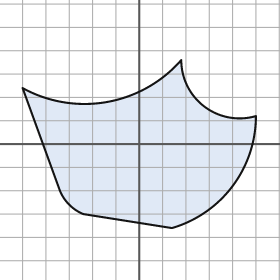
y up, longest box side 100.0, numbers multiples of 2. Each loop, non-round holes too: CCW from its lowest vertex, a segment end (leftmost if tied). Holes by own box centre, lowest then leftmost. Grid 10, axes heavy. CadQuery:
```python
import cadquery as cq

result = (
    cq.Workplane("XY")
    .moveTo(14.0, -36.0)
    .threePointArc((40.0, -18.0), (50.0, 12.0))
    .threePointArc((28.0, 16.0), (18.0, 36.0))
    .threePointArc((-14.0, 18.0), (-50.0, 24.0))
    .lineTo(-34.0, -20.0)
    .threePointArc((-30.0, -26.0), (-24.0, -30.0))
    .close()
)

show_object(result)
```